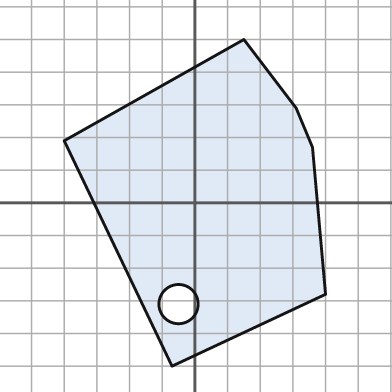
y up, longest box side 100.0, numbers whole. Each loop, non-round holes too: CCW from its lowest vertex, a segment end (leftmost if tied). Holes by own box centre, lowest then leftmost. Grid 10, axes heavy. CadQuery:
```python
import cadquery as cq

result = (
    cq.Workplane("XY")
    .moveTo(-7.0, -50.0)
    .lineTo(40.0, -28.0)
    .lineTo(36.0, 17.0)
    .lineTo(31.0, 29.0)
    .lineTo(15.0, 50.0)
    .lineTo(-40.0, 19.0)
    .close()
    .moveTo(-5.0, -31.0)
    .circle(6.0)
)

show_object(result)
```